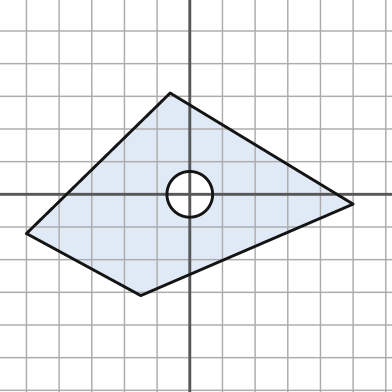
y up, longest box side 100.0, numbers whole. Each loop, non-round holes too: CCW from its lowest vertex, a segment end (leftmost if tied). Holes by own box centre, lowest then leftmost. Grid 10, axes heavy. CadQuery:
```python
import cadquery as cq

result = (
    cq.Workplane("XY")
    .moveTo(-15.0, -31.0)
    .lineTo(50.0, -3.0)
    .lineTo(-6.0, 31.0)
    .lineTo(-50.0, -12.0)
    .close()
    .moveTo(0.0, 0.0)
    .circle(7.0)
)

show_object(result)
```